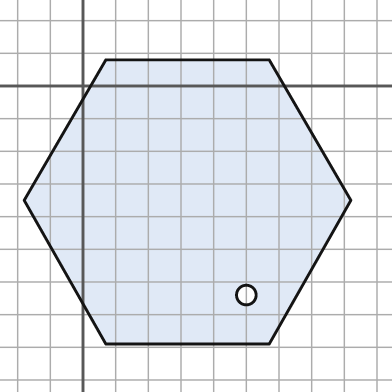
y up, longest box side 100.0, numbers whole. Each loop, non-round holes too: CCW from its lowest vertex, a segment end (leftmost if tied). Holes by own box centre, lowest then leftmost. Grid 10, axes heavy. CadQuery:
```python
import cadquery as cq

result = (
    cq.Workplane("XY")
    .moveTo(7.0, -79.0)
    .lineTo(57.0, -79.0)
    .lineTo(82.0, -35.0)
    .lineTo(57.0, 8.0)
    .lineTo(7.0, 8.0)
    .lineTo(-18.0, -35.0)
    .close()
    .moveTo(50.0, -64.0)
    .circle(3.0)
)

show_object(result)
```